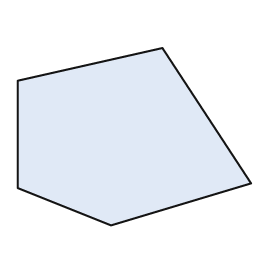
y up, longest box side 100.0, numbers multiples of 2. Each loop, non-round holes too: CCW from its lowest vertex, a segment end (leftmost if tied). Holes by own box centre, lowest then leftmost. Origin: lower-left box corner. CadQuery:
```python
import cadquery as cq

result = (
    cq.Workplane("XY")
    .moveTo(40.0, 0.0)
    .lineTo(100.0, 18.0)
    .lineTo(62.0, 76.0)
    .lineTo(0.0, 62.0)
    .lineTo(0.0, 16.0)
    .close()
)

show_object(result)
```